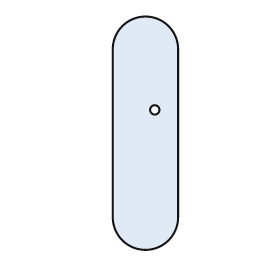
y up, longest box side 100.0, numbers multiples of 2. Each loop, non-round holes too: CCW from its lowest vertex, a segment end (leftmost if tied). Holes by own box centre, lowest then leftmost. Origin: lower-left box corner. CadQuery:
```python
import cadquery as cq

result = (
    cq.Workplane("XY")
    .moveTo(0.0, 14.0)
    .threePointArc((14.0, 0.0), (28.0, 14.0))
    .lineTo(28.0, 86.0)
    .threePointArc((14.0, 100.0), (0.0, 86.0))
    .close()
    .moveTo(18.0, 60.0)
    .circle(2.0)
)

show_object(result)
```